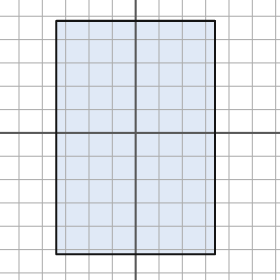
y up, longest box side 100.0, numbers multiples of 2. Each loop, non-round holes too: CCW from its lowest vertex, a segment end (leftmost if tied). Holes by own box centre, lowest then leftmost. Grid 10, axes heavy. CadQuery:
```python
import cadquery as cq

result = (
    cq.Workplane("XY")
    .moveTo(-34.0, -52.0)
    .lineTo(34.0, -52.0)
    .lineTo(34.0, 48.0)
    .lineTo(-34.0, 48.0)
    .close()
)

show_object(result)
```